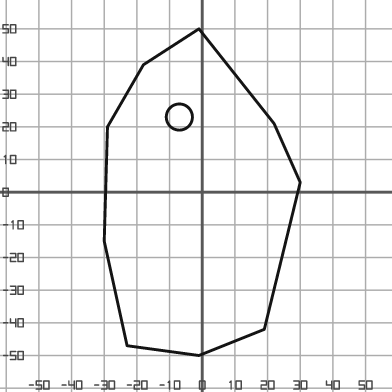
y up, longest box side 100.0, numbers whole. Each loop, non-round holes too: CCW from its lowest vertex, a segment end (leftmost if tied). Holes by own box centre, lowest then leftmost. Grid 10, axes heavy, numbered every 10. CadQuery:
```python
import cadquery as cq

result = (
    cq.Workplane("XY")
    .moveTo(-1.0, -50.0)
    .lineTo(19.0, -42.0)
    .lineTo(30.0, 3.0)
    .lineTo(22.0, 21.0)
    .lineTo(-1.0, 50.0)
    .lineTo(-18.0, 39.0)
    .lineTo(-29.0, 20.0)
    .lineTo(-30.0, -15.0)
    .lineTo(-23.0, -47.0)
    .close()
    .moveTo(-7.0, 23.0)
    .circle(4.0)
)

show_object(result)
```